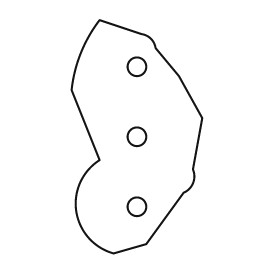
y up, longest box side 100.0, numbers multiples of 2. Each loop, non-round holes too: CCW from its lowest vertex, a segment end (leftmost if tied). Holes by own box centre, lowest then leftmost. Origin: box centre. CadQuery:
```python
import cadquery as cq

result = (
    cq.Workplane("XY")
    .moveTo(-10.0, -50.0)
    .lineTo(4.0, -46.0)
    .lineTo(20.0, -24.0)
    .threePointArc((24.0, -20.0), (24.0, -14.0))
    .lineTo(28.0, 8.0)
    .lineTo(18.0, 26.0)
    .lineTo(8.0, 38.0)
    .threePointArc((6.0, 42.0), (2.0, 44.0))
    .lineTo(-16.0, 50.0)
    .threePointArc((-24.0, 36.0), (-28.0, 20.0))
    .lineTo(-16.0, -10.0)
    .threePointArc((-26.0, -32.0), (-10.0, -50.0))
    .close()
    .moveTo(0.0, -30.0)
    .circle(4.0)
    .moveTo(0.0, 0.0)
    .circle(4.0)
    .moveTo(0.0, 30.0)
    .circle(4.0)
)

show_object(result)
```